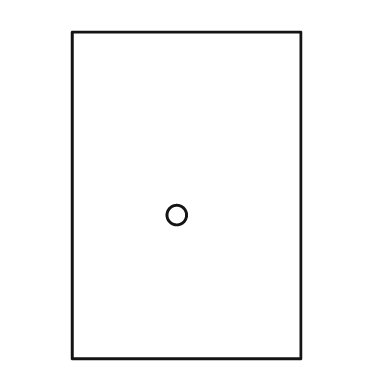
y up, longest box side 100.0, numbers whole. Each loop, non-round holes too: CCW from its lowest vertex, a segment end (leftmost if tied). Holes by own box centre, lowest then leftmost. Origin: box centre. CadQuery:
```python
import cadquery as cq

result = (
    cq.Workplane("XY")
    .moveTo(-35.0, -50.0)
    .lineTo(35.0, -50.0)
    .lineTo(35.0, 50.0)
    .lineTo(-35.0, 50.0)
    .close()
    .moveTo(-3.0, -6.0)
    .circle(3.0)
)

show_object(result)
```